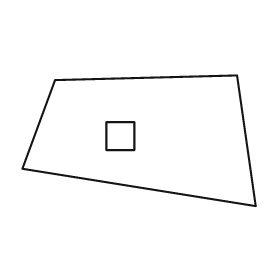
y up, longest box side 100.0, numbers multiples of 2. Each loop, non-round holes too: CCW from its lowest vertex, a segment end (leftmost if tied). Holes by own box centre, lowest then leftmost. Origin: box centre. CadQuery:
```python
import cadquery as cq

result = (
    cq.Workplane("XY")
    .moveTo(50.0, -28.0)
    .lineTo(42.0, 28.0)
    .lineTo(-36.0, 26.0)
    .lineTo(-50.0, -12.0)
    .close()
    .moveTo(-14.0, -4.0)
    .lineTo(-2.0, -4.0)
    .lineTo(-2.0, 8.0)
    .lineTo(-14.0, 8.0)
    .close()
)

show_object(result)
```